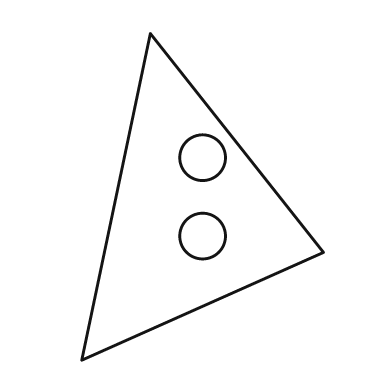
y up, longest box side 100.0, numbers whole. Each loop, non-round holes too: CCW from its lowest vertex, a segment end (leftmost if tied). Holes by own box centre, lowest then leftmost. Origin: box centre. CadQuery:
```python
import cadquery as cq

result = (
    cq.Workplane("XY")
    .moveTo(-37.0, -50.0)
    .lineTo(37.0, -17.0)
    .lineTo(-16.0, 50.0)
    .close()
    .moveTo(0.0, -12.0)
    .circle(7.0)
    .moveTo(0.0, 12.0)
    .circle(7.0)
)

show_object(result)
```